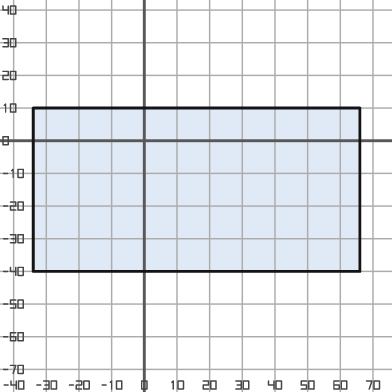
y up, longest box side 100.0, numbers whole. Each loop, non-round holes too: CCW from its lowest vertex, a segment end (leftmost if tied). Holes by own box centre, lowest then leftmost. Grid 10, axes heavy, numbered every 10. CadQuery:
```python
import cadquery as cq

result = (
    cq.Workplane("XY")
    .moveTo(-34.0, -40.0)
    .lineTo(66.0, -40.0)
    .lineTo(66.0, 10.0)
    .lineTo(-34.0, 10.0)
    .close()
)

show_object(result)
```